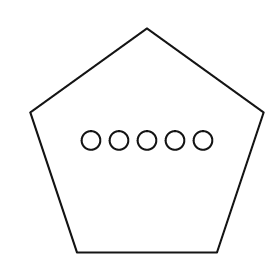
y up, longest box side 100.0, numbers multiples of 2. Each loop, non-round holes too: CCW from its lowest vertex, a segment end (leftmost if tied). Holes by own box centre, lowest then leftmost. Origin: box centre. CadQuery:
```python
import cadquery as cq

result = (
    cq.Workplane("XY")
    .moveTo(-30.0, -48.0)
    .lineTo(30.0, -48.0)
    .lineTo(50.0, 12.0)
    .lineTo(0.0, 48.0)
    .lineTo(-50.0, 12.0)
    .close()
    .moveTo(-24.0, 0.0)
    .circle(4.0)
    .moveTo(-12.0, 0.0)
    .circle(4.0)
    .moveTo(0.0, 0.0)
    .circle(4.0)
    .moveTo(12.0, 0.0)
    .circle(4.0)
    .moveTo(24.0, 0.0)
    .circle(4.0)
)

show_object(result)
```